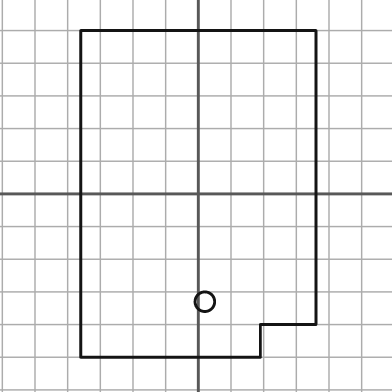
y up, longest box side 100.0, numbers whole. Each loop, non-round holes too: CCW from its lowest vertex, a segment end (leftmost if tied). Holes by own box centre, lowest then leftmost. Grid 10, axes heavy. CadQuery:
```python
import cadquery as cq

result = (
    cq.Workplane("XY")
    .moveTo(-36.0, -50.0)
    .lineTo(19.0, -50.0)
    .lineTo(19.0, -40.0)
    .lineTo(36.0, -40.0)
    .lineTo(36.0, 50.0)
    .lineTo(-36.0, 50.0)
    .close()
    .moveTo(2.0, -33.0)
    .circle(3.0)
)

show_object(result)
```